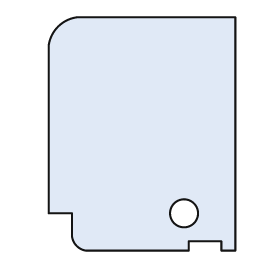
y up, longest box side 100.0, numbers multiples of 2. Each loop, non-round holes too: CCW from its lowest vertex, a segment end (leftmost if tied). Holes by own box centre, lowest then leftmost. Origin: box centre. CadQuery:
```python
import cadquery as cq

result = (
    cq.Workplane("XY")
    .moveTo(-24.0, -50.0)
    .lineTo(20.0, -50.0)
    .lineTo(20.0, -46.0)
    .lineTo(34.0, -46.0)
    .lineTo(34.0, -50.0)
    .lineTo(40.0, -50.0)
    .lineTo(40.0, 50.0)
    .lineTo(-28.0, 50.0)
    .threePointArc((-36.0, 46.0), (-40.0, 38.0))
    .lineTo(-40.0, -34.0)
    .lineTo(-30.0, -34.0)
    .lineTo(-30.0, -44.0)
    .threePointArc((-28.0, -48.0), (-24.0, -50.0))
    .close()
    .moveTo(18.0, -34.0)
    .circle(6.0)
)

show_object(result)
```